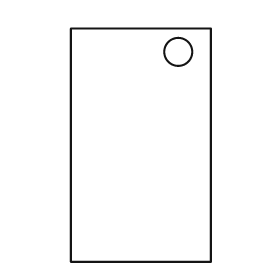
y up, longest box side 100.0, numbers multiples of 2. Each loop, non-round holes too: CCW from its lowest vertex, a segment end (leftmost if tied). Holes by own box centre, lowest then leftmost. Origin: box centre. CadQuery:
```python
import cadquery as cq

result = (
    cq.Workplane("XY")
    .moveTo(-30.0, -50.0)
    .lineTo(30.0, -50.0)
    .lineTo(30.0, 50.0)
    .lineTo(-30.0, 50.0)
    .close()
    .moveTo(16.0, 40.0)
    .circle(6.0)
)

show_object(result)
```